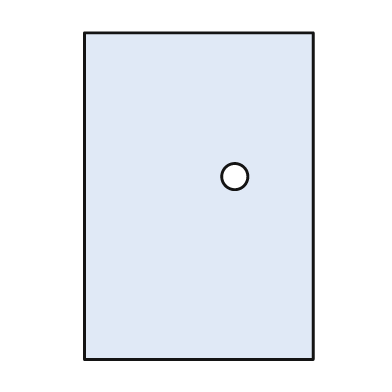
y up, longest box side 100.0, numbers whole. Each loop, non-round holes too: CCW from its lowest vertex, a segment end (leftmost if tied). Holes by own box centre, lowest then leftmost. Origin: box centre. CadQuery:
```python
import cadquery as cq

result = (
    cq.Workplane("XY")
    .moveTo(-35.0, -50.0)
    .lineTo(35.0, -50.0)
    .lineTo(35.0, 50.0)
    .lineTo(-35.0, 50.0)
    .close()
    .moveTo(11.0, 6.0)
    .circle(4.0)
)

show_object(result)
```